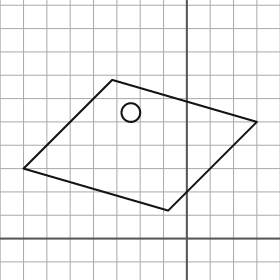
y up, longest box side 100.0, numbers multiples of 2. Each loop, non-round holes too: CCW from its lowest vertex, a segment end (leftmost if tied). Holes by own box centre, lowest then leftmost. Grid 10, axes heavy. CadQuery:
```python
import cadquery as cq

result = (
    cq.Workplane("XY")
    .moveTo(-8.0, 12.0)
    .lineTo(30.0, 50.0)
    .lineTo(-32.0, 68.0)
    .lineTo(-70.0, 30.0)
    .close()
    .moveTo(-24.0, 54.0)
    .circle(4.0)
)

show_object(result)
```